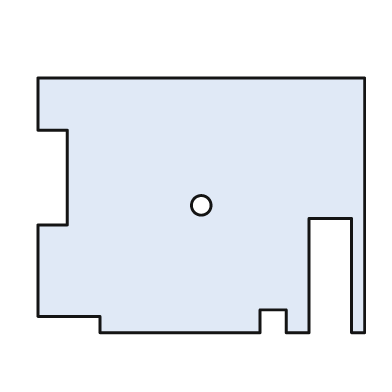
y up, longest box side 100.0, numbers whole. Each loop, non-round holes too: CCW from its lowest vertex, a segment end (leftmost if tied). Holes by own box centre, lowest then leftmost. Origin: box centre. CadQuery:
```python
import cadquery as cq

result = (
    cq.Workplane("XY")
    .moveTo(-31.0, -39.0)
    .lineTo(18.0, -39.0)
    .lineTo(18.0, -32.0)
    .lineTo(26.0, -32.0)
    .lineTo(26.0, -39.0)
    .lineTo(33.0, -39.0)
    .lineTo(33.0, -4.0)
    .lineTo(46.0, -4.0)
    .lineTo(46.0, -39.0)
    .lineTo(50.0, -39.0)
    .lineTo(50.0, 39.0)
    .lineTo(-50.0, 39.0)
    .lineTo(-50.0, 23.0)
    .lineTo(-41.0, 23.0)
    .lineTo(-41.0, -6.0)
    .lineTo(-50.0, -6.0)
    .lineTo(-50.0, -34.0)
    .lineTo(-31.0, -34.0)
    .close()
    .moveTo(0.0, 0.0)
    .circle(3.0)
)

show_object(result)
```